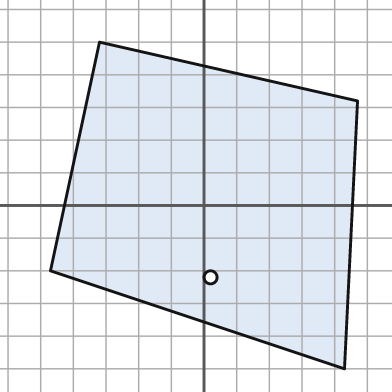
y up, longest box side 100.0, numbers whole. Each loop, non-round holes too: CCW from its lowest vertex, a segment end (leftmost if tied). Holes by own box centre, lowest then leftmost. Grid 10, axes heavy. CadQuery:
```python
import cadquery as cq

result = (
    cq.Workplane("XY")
    .moveTo(43.0, -50.0)
    .lineTo(47.0, 32.0)
    .lineTo(-32.0, 50.0)
    .lineTo(-47.0, -20.0)
    .close()
    .moveTo(2.0, -22.0)
    .circle(2.0)
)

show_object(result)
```